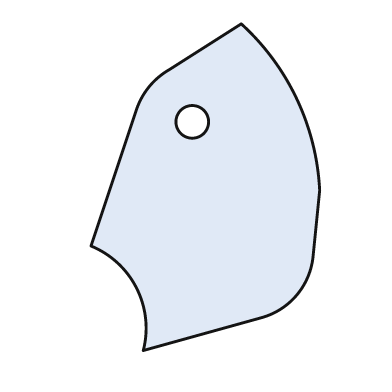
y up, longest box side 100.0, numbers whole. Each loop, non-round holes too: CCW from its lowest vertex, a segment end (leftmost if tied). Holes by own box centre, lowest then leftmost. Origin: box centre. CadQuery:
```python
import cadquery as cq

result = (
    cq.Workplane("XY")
    .moveTo(-19.0, -50.0)
    .lineTo(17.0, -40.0)
    .threePointArc((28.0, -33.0), (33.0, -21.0))
    .lineTo(35.0, -1.0)
    .threePointArc((28.0, 27.0), (11.0, 50.0))
    .lineTo(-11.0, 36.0)
    .threePointArc((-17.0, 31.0), (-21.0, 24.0))
    .lineTo(-35.0, -18.0)
    .threePointArc((-21.0, -31.0), (-19.0, -50.0))
    .close()
    .moveTo(-4.0, 20.0)
    .circle(5.0)
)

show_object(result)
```